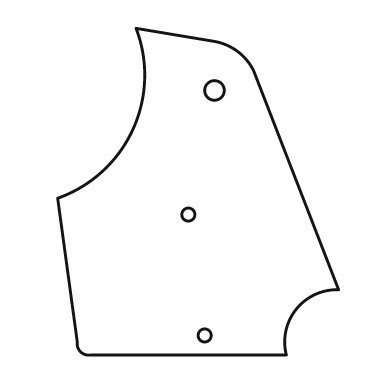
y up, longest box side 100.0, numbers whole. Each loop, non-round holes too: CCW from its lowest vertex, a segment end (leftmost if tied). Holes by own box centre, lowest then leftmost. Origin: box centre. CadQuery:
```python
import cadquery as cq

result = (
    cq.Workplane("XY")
    .moveTo(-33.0, -50.0)
    .lineTo(27.0, -50.0)
    .threePointArc((30.0, -36.0), (43.0, -30.0))
    .lineTo(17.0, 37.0)
    .threePointArc((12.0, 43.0), (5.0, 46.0))
    .lineTo(-19.0, 50.0)
    .threePointArc((-20.0, 19.0), (-43.0, -2.0))
    .lineTo(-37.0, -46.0)
    .threePointArc((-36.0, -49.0), (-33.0, -50.0))
    .close()
    .moveTo(2.0, -44.0)
    .circle(2.0)
    .moveTo(-3.0, -7.0)
    .circle(2.0)
    .moveTo(5.0, 31.0)
    .circle(3.0)
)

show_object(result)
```